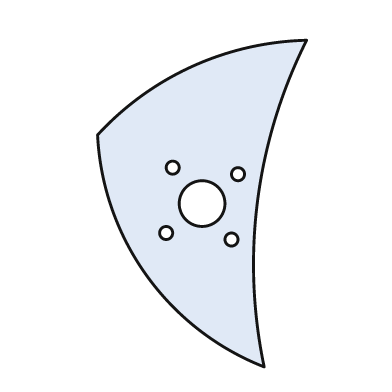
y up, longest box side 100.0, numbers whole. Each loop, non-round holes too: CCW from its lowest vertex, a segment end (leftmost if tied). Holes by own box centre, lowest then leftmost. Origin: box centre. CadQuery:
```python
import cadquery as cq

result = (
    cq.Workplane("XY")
    .moveTo(19.0, -50.0)
    .threePointArc((17.0, 1.0), (32.0, 50.0))
    .threePointArc((-3.0, 42.0), (-32.0, 21.0))
    .threePointArc((-17.0, -22.0), (19.0, -50.0))
    .close()
    .moveTo(9.0, -11.0)
    .circle(2.0)
    .moveTo(-11.0, -9.0)
    .circle(2.0)
    .moveTo(0.0, 0.0)
    .circle(7.0)
    .moveTo(11.0, 9.0)
    .circle(2.0)
    .moveTo(-9.0, 11.0)
    .circle(2.0)
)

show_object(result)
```